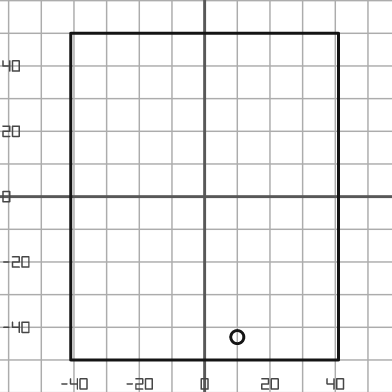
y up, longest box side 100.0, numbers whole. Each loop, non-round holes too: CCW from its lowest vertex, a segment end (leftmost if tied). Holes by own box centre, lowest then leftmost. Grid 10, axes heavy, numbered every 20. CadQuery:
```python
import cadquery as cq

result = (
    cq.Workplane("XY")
    .moveTo(-41.0, -50.0)
    .lineTo(41.0, -50.0)
    .lineTo(41.0, 50.0)
    .lineTo(-41.0, 50.0)
    .close()
    .moveTo(10.0, -43.0)
    .circle(2.0)
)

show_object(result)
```